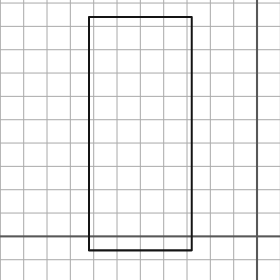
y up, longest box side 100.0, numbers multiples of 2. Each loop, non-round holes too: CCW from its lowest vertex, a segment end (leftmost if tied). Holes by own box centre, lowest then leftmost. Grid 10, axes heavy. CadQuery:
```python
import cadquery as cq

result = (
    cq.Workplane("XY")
    .moveTo(-72.0, -6.0)
    .lineTo(-28.0, -6.0)
    .lineTo(-28.0, 94.0)
    .lineTo(-72.0, 94.0)
    .close()
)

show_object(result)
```